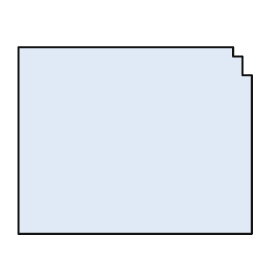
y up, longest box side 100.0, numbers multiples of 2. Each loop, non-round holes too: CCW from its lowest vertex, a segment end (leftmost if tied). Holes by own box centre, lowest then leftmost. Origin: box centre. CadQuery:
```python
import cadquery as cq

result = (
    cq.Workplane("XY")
    .moveTo(-50.0, -40.0)
    .lineTo(50.0, -40.0)
    .lineTo(50.0, 28.0)
    .lineTo(46.0, 28.0)
    .lineTo(46.0, 36.0)
    .lineTo(42.0, 36.0)
    .lineTo(42.0, 40.0)
    .lineTo(-50.0, 40.0)
    .close()
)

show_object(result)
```